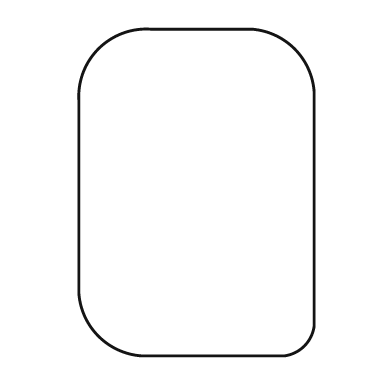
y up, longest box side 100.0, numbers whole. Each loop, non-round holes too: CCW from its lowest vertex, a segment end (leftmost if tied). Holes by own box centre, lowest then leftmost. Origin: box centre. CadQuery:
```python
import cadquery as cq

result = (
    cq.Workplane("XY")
    .moveTo(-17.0, -50.0)
    .lineTo(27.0, -50.0)
    .threePointArc((33.0, -47.0), (36.0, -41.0))
    .lineTo(36.0, 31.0)
    .threePointArc((30.0, 44.0), (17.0, 50.0))
    .lineTo(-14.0, 50.0)
    .threePointArc((-30.0, 44.0), (-36.0, 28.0))
    .lineTo(-36.0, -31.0)
    .threePointArc((-30.0, -44.0), (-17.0, -50.0))
    .close()
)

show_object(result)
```